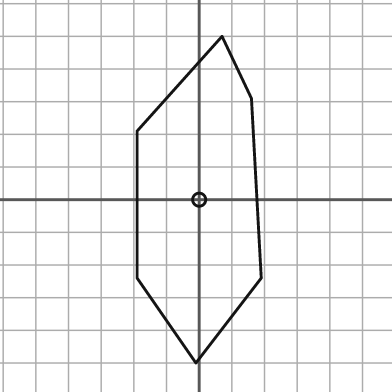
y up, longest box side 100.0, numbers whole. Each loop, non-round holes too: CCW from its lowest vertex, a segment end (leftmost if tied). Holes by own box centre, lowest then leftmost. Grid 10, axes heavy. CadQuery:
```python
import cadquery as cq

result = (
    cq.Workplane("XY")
    .moveTo(-1.0, -50.0)
    .lineTo(19.0, -24.0)
    .lineTo(16.0, 31.0)
    .lineTo(7.0, 50.0)
    .lineTo(-19.0, 21.0)
    .lineTo(-19.0, -24.0)
    .close()
    .moveTo(0.0, 0.0)
    .circle(2.0)
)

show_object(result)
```